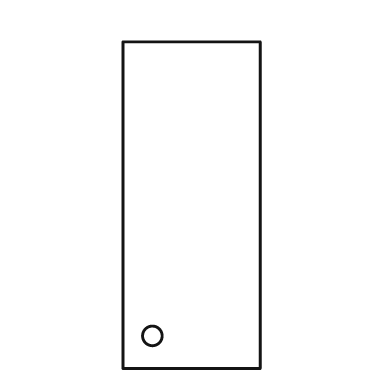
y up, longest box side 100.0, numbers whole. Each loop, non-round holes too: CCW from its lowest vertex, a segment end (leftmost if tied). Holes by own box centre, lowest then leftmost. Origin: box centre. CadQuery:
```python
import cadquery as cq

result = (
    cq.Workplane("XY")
    .moveTo(-21.0, -50.0)
    .lineTo(21.0, -50.0)
    .lineTo(21.0, 50.0)
    .lineTo(-21.0, 50.0)
    .close()
    .moveTo(-12.0, -40.0)
    .circle(3.0)
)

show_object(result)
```